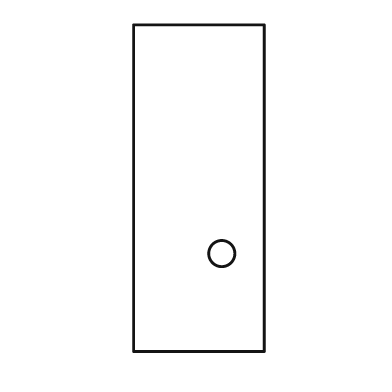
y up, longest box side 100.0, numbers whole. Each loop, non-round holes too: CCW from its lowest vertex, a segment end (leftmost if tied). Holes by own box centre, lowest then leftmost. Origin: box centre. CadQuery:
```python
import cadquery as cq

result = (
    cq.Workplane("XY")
    .moveTo(-20.0, -50.0)
    .lineTo(20.0, -50.0)
    .lineTo(20.0, 50.0)
    .lineTo(-20.0, 50.0)
    .close()
    .moveTo(7.0, -20.0)
    .circle(4.0)
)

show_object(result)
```